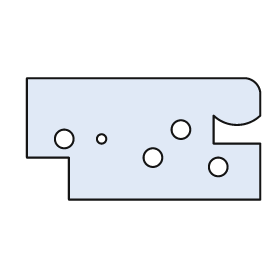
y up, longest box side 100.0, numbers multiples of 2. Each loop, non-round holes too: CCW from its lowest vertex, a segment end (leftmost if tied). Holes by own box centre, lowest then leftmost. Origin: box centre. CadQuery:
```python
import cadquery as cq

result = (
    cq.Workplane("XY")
    .moveTo(-32.0, -26.0)
    .lineTo(50.0, -26.0)
    .lineTo(50.0, -2.0)
    .lineTo(30.0, -2.0)
    .lineTo(30.0, 10.0)
    .threePointArc((40.0, 6.0), (50.0, 10.0))
    .lineTo(50.0, 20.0)
    .threePointArc((48.0, 24.0), (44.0, 26.0))
    .lineTo(-50.0, 26.0)
    .lineTo(-50.0, -8.0)
    .lineTo(-32.0, -8.0)
    .close()
    .moveTo(32.0, -12.0)
    .circle(4.0)
    .moveTo(4.0, -8.0)
    .circle(4.0)
    .moveTo(-34.0, 0.0)
    .circle(4.0)
    .moveTo(-18.0, 0.0)
    .circle(2.0)
    .moveTo(16.0, 4.0)
    .circle(4.0)
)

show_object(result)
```